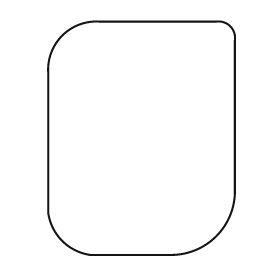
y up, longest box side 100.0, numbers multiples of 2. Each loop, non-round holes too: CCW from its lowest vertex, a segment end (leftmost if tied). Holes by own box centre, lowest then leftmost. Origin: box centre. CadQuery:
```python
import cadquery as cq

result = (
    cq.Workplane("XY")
    .moveTo(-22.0, -50.0)
    .lineTo(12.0, -50.0)
    .threePointArc((32.0, -42.0), (40.0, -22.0))
    .lineTo(40.0, 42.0)
    .threePointArc((38.0, 48.0), (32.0, 50.0))
    .lineTo(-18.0, 50.0)
    .threePointArc((-34.0, 44.0), (-40.0, 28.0))
    .lineTo(-40.0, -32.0)
    .threePointArc((-34.0, -44.0), (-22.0, -50.0))
    .close()
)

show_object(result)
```